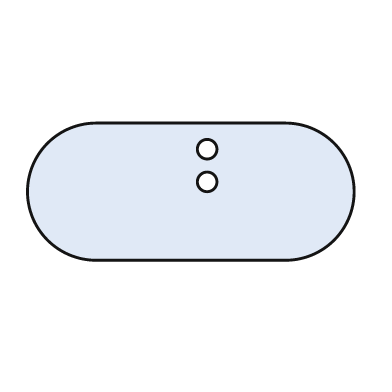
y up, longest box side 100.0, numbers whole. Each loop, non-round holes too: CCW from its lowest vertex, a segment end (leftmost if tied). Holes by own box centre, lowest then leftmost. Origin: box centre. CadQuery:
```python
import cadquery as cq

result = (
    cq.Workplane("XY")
    .moveTo(-29.0, -21.0)
    .lineTo(29.0, -21.0)
    .threePointArc((50.0, 0.0), (29.0, 21.0))
    .lineTo(-29.0, 21.0)
    .threePointArc((-50.0, 0.0), (-29.0, -21.0))
    .close()
    .moveTo(5.0, 3.0)
    .circle(3.0)
    .moveTo(5.0, 13.0)
    .circle(3.0)
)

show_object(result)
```